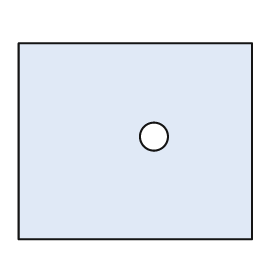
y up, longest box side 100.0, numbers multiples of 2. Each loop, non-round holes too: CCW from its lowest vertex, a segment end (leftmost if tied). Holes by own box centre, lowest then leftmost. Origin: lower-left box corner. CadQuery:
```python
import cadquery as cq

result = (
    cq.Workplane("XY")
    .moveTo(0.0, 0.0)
    .lineTo(100.0, 0.0)
    .lineTo(100.0, 84.0)
    .lineTo(0.0, 84.0)
    .close()
    .moveTo(58.0, 44.0)
    .circle(6.0)
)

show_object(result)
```